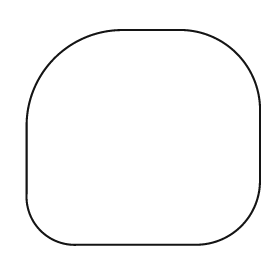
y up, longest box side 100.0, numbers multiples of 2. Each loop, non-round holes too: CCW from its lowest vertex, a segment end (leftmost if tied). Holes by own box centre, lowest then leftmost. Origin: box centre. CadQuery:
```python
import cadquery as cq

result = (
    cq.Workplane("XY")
    .moveTo(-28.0, -46.0)
    .lineTo(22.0, -46.0)
    .threePointArc((42.0, -38.0), (50.0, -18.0))
    .lineTo(50.0, 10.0)
    .threePointArc((40.0, 36.0), (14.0, 46.0))
    .lineTo(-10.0, 46.0)
    .threePointArc((-38.0, 34.0), (-50.0, 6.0))
    .lineTo(-50.0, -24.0)
    .threePointArc((-44.0, -40.0), (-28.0, -46.0))
    .close()
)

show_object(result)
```